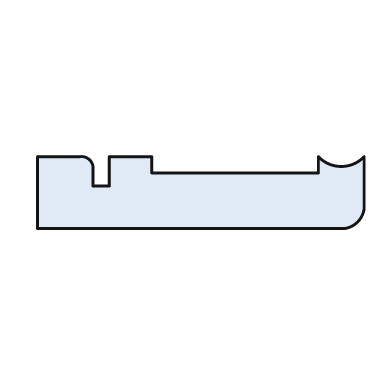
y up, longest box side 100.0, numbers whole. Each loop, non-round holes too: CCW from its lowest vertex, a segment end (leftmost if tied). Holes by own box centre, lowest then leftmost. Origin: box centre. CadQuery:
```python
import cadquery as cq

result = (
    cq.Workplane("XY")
    .moveTo(-50.0, -11.0)
    .lineTo(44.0, -11.0)
    .threePointArc((48.0, -9.0), (50.0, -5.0))
    .lineTo(50.0, 11.0)
    .threePointArc((43.0, 8.0), (36.0, 11.0))
    .lineTo(36.0, 6.0)
    .lineTo(-15.0, 6.0)
    .lineTo(-15.0, 11.0)
    .lineTo(-28.0, 11.0)
    .lineTo(-28.0, 2.0)
    .lineTo(-33.0, 2.0)
    .lineTo(-33.0, 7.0)
    .threePointArc((-34.0, 10.0), (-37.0, 11.0))
    .lineTo(-50.0, 11.0)
    .close()
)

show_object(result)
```